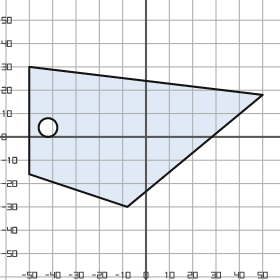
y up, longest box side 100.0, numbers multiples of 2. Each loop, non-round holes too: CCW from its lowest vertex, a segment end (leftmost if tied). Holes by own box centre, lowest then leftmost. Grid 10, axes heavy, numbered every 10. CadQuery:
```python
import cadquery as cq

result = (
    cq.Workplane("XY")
    .moveTo(-8.0, -30.0)
    .lineTo(50.0, 18.0)
    .lineTo(-50.0, 30.0)
    .lineTo(-50.0, -16.0)
    .close()
    .moveTo(-42.0, 4.0)
    .circle(4.0)
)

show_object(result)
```